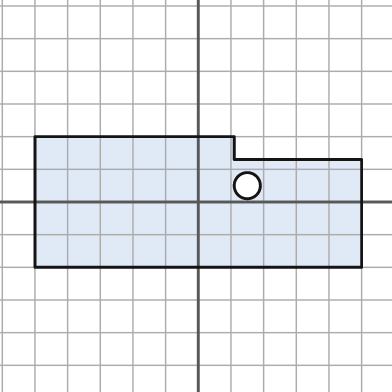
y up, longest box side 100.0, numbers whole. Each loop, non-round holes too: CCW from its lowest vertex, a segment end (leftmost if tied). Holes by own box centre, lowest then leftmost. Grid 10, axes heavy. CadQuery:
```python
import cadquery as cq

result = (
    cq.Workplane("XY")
    .moveTo(-50.0, -20.0)
    .lineTo(50.0, -20.0)
    .lineTo(50.0, 13.0)
    .lineTo(11.0, 13.0)
    .lineTo(11.0, 20.0)
    .lineTo(-50.0, 20.0)
    .close()
    .moveTo(15.0, 5.0)
    .circle(4.0)
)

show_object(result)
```